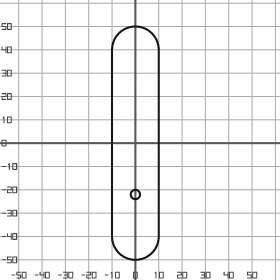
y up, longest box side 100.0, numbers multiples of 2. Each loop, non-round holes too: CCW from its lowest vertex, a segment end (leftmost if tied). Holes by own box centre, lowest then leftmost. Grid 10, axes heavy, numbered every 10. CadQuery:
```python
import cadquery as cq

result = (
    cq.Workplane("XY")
    .moveTo(-10.0, -40.0)
    .threePointArc((0.0, -50.0), (10.0, -40.0))
    .lineTo(10.0, 40.0)
    .threePointArc((0.0, 50.0), (-10.0, 40.0))
    .close()
    .moveTo(0.0, -22.0)
    .circle(2.0)
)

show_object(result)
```